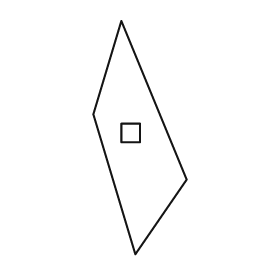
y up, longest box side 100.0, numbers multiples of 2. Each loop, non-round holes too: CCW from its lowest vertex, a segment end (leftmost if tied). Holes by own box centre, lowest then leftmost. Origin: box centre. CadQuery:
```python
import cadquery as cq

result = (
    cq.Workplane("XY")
    .moveTo(-2.0, -50.0)
    .lineTo(20.0, -18.0)
    .lineTo(-8.0, 50.0)
    .lineTo(-20.0, 10.0)
    .close()
    .moveTo(-8.0, -2.0)
    .lineTo(0.0, -2.0)
    .lineTo(0.0, 6.0)
    .lineTo(-8.0, 6.0)
    .close()
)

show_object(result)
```